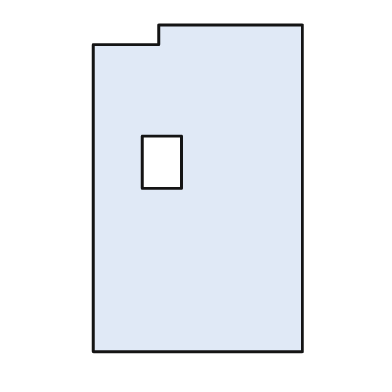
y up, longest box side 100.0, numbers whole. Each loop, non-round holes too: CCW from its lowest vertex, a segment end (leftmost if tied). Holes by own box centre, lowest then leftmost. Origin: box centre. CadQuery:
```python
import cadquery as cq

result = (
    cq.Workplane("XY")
    .moveTo(-32.0, -50.0)
    .lineTo(32.0, -50.0)
    .lineTo(32.0, 50.0)
    .lineTo(-12.0, 50.0)
    .lineTo(-12.0, 44.0)
    .lineTo(-32.0, 44.0)
    .close()
    .moveTo(-17.0, 0.0)
    .lineTo(-5.0, 0.0)
    .lineTo(-5.0, 16.0)
    .lineTo(-17.0, 16.0)
    .close()
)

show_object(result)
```